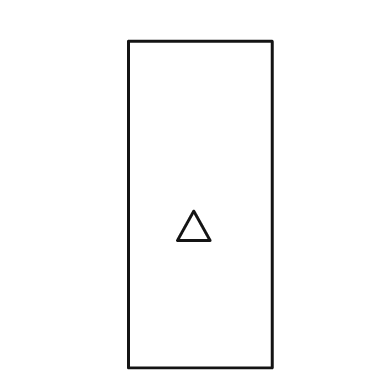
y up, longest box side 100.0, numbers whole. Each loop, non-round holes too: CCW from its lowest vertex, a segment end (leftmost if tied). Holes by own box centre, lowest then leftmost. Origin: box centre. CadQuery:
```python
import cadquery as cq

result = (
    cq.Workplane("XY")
    .moveTo(-22.0, -50.0)
    .lineTo(22.0, -50.0)
    .lineTo(22.0, 50.0)
    .lineTo(-22.0, 50.0)
    .close()
    .moveTo(-7.0, -11.0)
    .lineTo(3.0, -11.0)
    .lineTo(-2.0, -2.0)
    .close()
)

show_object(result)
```